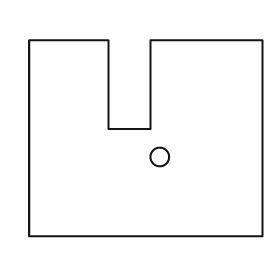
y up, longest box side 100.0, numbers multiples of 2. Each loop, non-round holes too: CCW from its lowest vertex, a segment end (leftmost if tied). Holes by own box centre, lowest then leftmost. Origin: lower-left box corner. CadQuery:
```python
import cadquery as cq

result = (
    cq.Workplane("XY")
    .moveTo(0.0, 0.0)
    .lineTo(100.0, 0.0)
    .lineTo(100.0, 84.0)
    .lineTo(52.0, 84.0)
    .lineTo(52.0, 46.0)
    .lineTo(34.0, 46.0)
    .lineTo(34.0, 84.0)
    .lineTo(0.0, 84.0)
    .close()
    .moveTo(56.0, 34.0)
    .circle(4.0)
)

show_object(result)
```